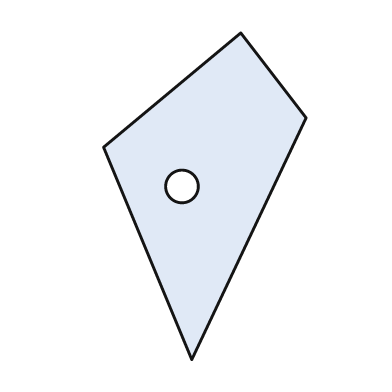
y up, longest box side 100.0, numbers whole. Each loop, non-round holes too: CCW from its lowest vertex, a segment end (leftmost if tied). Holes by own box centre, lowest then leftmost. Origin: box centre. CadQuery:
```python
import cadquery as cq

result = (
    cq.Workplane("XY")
    .moveTo(-4.0, -50.0)
    .lineTo(31.0, 24.0)
    .lineTo(11.0, 50.0)
    .lineTo(-31.0, 15.0)
    .close()
    .moveTo(-7.0, 3.0)
    .circle(5.0)
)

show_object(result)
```